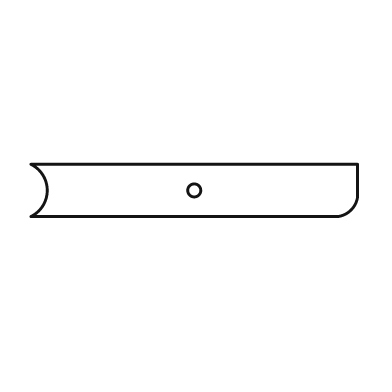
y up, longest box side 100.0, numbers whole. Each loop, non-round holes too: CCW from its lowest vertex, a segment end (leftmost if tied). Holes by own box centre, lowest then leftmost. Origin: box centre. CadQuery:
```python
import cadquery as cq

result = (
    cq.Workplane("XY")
    .moveTo(-50.0, -8.0)
    .lineTo(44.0, -8.0)
    .threePointArc((48.0, -6.0), (50.0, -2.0))
    .lineTo(50.0, 8.0)
    .lineTo(-50.0, 8.0)
    .threePointArc((-45.0, 0.0), (-50.0, -8.0))
    .close()
    .moveTo(0.0, 0.0)
    .circle(2.0)
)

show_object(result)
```